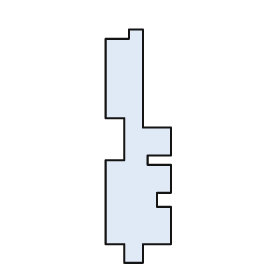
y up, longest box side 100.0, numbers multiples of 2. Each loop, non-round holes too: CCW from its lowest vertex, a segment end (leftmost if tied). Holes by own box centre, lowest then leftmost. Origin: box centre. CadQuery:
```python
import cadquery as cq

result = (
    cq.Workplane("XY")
    .moveTo(-6.0, -50.0)
    .lineTo(2.0, -50.0)
    .lineTo(2.0, -42.0)
    .lineTo(14.0, -42.0)
    .lineTo(14.0, -26.0)
    .lineTo(8.0, -26.0)
    .lineTo(8.0, -20.0)
    .lineTo(14.0, -20.0)
    .lineTo(14.0, -8.0)
    .lineTo(4.0, -8.0)
    .lineTo(4.0, -4.0)
    .lineTo(14.0, -4.0)
    .lineTo(14.0, 8.0)
    .lineTo(2.0, 8.0)
    .lineTo(2.0, 50.0)
    .lineTo(-4.0, 50.0)
    .lineTo(-4.0, 46.0)
    .lineTo(-14.0, 46.0)
    .lineTo(-14.0, 12.0)
    .lineTo(-6.0, 12.0)
    .lineTo(-6.0, -6.0)
    .lineTo(-14.0, -6.0)
    .lineTo(-14.0, -42.0)
    .lineTo(-6.0, -42.0)
    .close()
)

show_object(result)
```